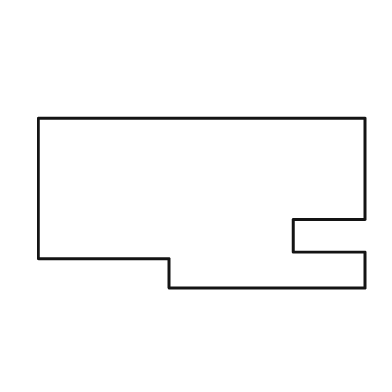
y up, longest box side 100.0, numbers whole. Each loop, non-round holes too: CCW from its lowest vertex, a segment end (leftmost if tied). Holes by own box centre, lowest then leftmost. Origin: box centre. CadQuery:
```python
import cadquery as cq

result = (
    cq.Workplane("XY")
    .moveTo(-10.0, -26.0)
    .lineTo(50.0, -26.0)
    .lineTo(50.0, -15.0)
    .lineTo(28.0, -15.0)
    .lineTo(28.0, -5.0)
    .lineTo(50.0, -5.0)
    .lineTo(50.0, 26.0)
    .lineTo(-50.0, 26.0)
    .lineTo(-50.0, -17.0)
    .lineTo(-10.0, -17.0)
    .close()
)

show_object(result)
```